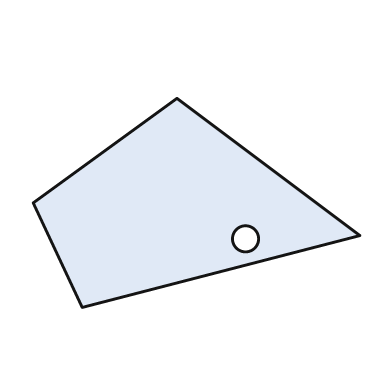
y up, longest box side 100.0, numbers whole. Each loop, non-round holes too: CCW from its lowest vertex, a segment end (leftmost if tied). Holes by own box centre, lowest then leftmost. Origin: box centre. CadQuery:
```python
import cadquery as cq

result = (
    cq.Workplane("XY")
    .moveTo(-35.0, -32.0)
    .lineTo(50.0, -10.0)
    .lineTo(-6.0, 32.0)
    .lineTo(-50.0, 0.0)
    .close()
    .moveTo(15.0, -11.0)
    .circle(4.0)
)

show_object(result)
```